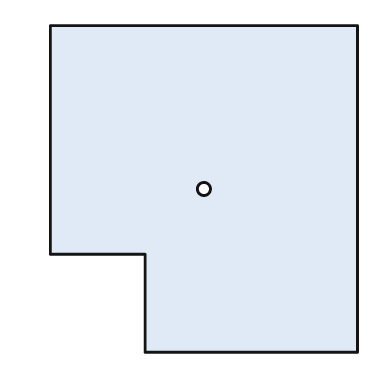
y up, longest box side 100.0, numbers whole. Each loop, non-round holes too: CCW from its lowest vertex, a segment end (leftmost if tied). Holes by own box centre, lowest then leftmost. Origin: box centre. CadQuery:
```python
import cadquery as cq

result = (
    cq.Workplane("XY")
    .moveTo(-18.0, -50.0)
    .lineTo(47.0, -50.0)
    .lineTo(47.0, 50.0)
    .lineTo(-47.0, 50.0)
    .lineTo(-47.0, -20.0)
    .lineTo(-18.0, -20.0)
    .close()
    .moveTo(0.0, 0.0)
    .circle(2.0)
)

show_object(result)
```